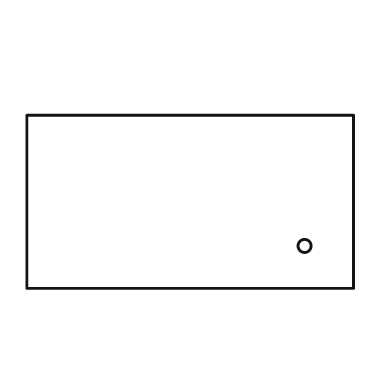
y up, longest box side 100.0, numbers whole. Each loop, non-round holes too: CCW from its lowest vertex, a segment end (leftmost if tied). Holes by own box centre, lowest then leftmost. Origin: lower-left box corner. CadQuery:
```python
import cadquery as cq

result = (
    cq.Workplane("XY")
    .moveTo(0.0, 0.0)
    .lineTo(100.0, 0.0)
    .lineTo(100.0, 53.0)
    .lineTo(0.0, 53.0)
    .close()
    .moveTo(85.0, 13.0)
    .circle(2.0)
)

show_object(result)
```